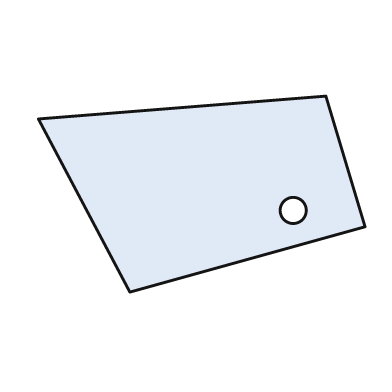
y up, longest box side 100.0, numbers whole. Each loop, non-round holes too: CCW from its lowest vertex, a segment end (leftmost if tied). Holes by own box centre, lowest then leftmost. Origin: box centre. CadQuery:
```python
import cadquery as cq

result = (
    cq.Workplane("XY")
    .moveTo(-22.0, -30.0)
    .lineTo(50.0, -10.0)
    .lineTo(38.0, 30.0)
    .lineTo(-50.0, 23.0)
    .close()
    .moveTo(28.0, -5.0)
    .circle(4.0)
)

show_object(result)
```